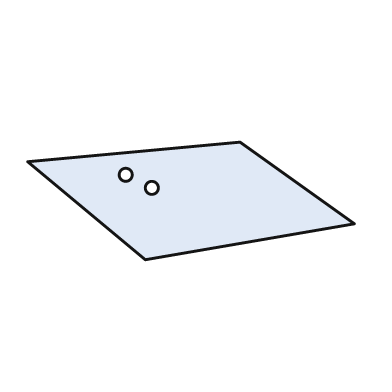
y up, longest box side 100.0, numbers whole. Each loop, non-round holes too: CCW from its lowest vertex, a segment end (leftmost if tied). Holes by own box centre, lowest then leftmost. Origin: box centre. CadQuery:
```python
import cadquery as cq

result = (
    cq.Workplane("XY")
    .moveTo(-14.0, -18.0)
    .lineTo(50.0, -7.0)
    .lineTo(15.0, 18.0)
    .lineTo(-50.0, 12.0)
    .close()
    .moveTo(-12.0, 4.0)
    .circle(2.0)
    .moveTo(-20.0, 8.0)
    .circle(2.0)
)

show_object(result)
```